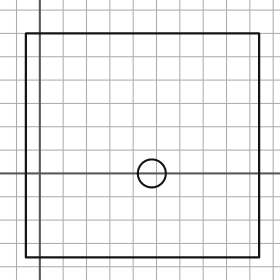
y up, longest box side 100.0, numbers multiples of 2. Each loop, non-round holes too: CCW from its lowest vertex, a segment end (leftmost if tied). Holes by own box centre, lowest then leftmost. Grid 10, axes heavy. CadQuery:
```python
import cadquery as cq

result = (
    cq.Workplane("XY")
    .moveTo(-6.0, -36.0)
    .lineTo(94.0, -36.0)
    .lineTo(94.0, 60.0)
    .lineTo(-6.0, 60.0)
    .close()
    .moveTo(48.0, 0.0)
    .circle(6.0)
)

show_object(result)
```